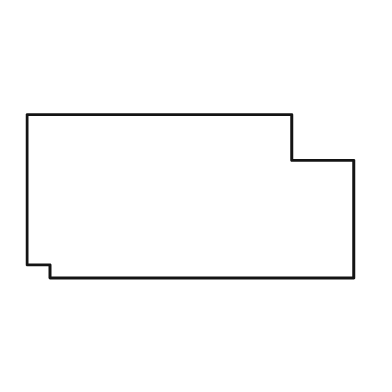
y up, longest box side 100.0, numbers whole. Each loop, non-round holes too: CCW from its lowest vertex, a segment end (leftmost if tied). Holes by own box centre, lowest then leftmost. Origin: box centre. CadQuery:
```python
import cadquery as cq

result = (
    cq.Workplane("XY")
    .moveTo(-43.0, -25.0)
    .lineTo(50.0, -25.0)
    .lineTo(50.0, 11.0)
    .lineTo(31.0, 11.0)
    .lineTo(31.0, 25.0)
    .lineTo(-50.0, 25.0)
    .lineTo(-50.0, -21.0)
    .lineTo(-43.0, -21.0)
    .close()
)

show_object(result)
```